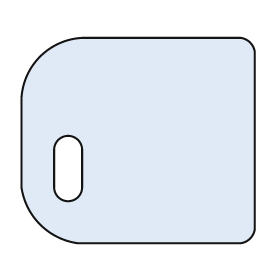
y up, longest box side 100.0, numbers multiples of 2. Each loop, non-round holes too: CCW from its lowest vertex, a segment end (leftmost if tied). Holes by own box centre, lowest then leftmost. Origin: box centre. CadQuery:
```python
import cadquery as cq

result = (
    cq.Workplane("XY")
    .moveTo(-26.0, -44.0)
    .lineTo(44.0, -44.0)
    .threePointArc((48.0, -42.0), (50.0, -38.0))
    .lineTo(50.0, 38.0)
    .threePointArc((48.0, 42.0), (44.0, 44.0))
    .lineTo(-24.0, 44.0)
    .threePointArc((-42.0, 36.0), (-50.0, 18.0))
    .lineTo(-50.0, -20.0)
    .threePointArc((-42.0, -36.0), (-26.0, -44.0))
    .close()
    .moveTo(-36.0, -20.0)
    .threePointArc((-30.0, -26.0), (-24.0, -20.0))
    .lineTo(-24.0, -4.0)
    .threePointArc((-30.0, 2.0), (-36.0, -4.0))
    .close()
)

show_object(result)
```